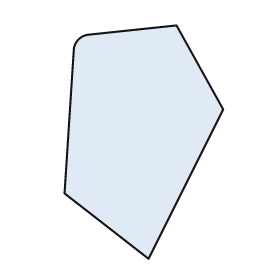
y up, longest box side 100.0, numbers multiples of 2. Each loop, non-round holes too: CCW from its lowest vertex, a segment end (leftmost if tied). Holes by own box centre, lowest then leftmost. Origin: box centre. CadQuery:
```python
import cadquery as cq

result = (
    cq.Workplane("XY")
    .moveTo(2.0, -50.0)
    .lineTo(34.0, 14.0)
    .lineTo(14.0, 50.0)
    .lineTo(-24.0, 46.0)
    .threePointArc((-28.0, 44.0), (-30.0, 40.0))
    .lineTo(-34.0, -22.0)
    .close()
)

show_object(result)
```